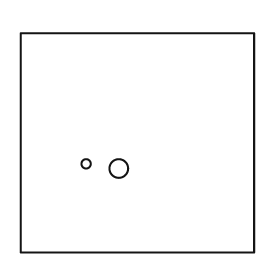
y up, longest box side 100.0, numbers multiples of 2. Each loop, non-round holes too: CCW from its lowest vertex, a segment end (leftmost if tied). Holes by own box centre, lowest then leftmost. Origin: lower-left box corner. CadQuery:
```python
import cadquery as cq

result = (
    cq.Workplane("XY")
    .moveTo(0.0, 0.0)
    .lineTo(100.0, 0.0)
    .lineTo(100.0, 94.0)
    .lineTo(0.0, 94.0)
    .close()
    .moveTo(42.0, 36.0)
    .circle(4.0)
    .moveTo(28.0, 38.0)
    .circle(2.0)
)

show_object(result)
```